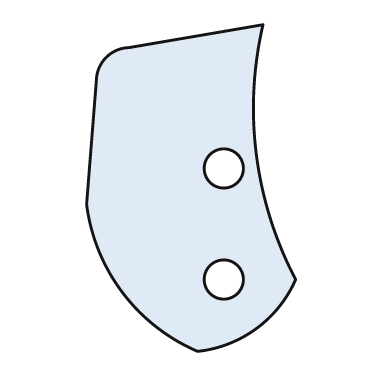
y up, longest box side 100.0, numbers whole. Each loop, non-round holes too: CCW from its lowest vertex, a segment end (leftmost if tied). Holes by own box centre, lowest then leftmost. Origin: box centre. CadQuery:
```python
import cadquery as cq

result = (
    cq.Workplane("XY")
    .moveTo(2.0, -50.0)
    .threePointArc((20.0, -43.0), (32.0, -28.0))
    .threePointArc((20.0, 10.0), (22.0, 50.0))
    .lineTo(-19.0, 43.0)
    .threePointArc((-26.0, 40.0), (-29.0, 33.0))
    .lineTo(-32.0, -5.0)
    .threePointArc((-21.0, -32.0), (2.0, -50.0))
    .close()
    .moveTo(10.0, -28.0)
    .circle(6.0)
    .moveTo(10.0, 6.0)
    .circle(6.0)
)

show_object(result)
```